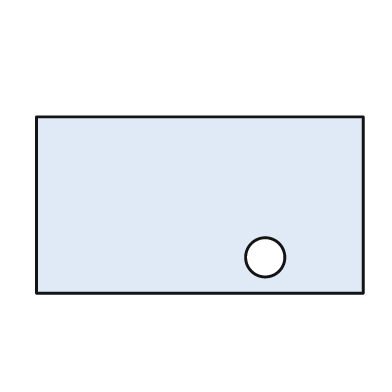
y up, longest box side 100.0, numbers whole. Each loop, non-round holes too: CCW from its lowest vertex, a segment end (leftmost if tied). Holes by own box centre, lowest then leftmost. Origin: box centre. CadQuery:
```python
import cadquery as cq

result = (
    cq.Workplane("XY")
    .moveTo(-50.0, -27.0)
    .lineTo(50.0, -27.0)
    .lineTo(50.0, 27.0)
    .lineTo(-50.0, 27.0)
    .close()
    .moveTo(20.0, -16.0)
    .circle(6.0)
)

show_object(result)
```